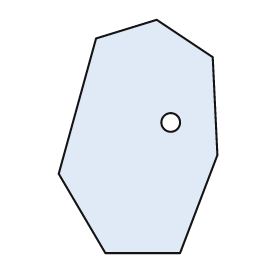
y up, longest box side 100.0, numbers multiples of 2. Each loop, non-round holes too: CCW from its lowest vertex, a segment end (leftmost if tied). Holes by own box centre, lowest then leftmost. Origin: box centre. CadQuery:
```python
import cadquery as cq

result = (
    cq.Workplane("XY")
    .moveTo(-14.0, -50.0)
    .lineTo(18.0, -50.0)
    .lineTo(34.0, -8.0)
    .lineTo(32.0, 34.0)
    .lineTo(8.0, 50.0)
    .lineTo(-18.0, 42.0)
    .lineTo(-34.0, -16.0)
    .close()
    .moveTo(14.0, 6.0)
    .circle(4.0)
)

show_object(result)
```